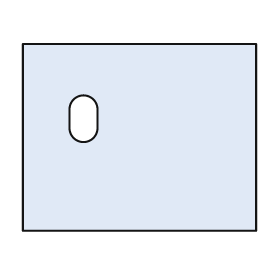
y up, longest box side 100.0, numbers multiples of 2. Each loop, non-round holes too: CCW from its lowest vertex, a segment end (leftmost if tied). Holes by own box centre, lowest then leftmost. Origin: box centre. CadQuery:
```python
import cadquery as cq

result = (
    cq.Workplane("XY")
    .moveTo(-50.0, -40.0)
    .lineTo(50.0, -40.0)
    .lineTo(50.0, 40.0)
    .lineTo(-50.0, 40.0)
    .close()
    .moveTo(-30.0, 4.0)
    .threePointArc((-24.0, -2.0), (-18.0, 4.0))
    .lineTo(-18.0, 12.0)
    .threePointArc((-24.0, 18.0), (-30.0, 12.0))
    .close()
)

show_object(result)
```